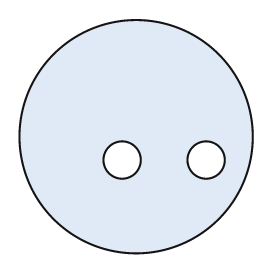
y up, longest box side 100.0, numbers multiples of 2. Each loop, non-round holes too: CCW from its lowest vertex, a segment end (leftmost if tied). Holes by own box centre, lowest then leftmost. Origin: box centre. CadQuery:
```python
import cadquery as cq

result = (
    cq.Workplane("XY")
    .moveTo(0.0, 0.0)
    .circle(50.0)
    .moveTo(-6.0, -10.0)
    .circle(8.0)
    .moveTo(30.0, -10.0)
    .circle(8.0)
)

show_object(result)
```